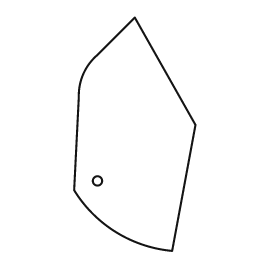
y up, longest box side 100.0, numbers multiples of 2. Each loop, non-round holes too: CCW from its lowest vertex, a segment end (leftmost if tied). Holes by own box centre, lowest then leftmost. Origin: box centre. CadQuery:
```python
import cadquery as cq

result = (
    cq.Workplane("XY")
    .moveTo(16.0, -50.0)
    .lineTo(26.0, 4.0)
    .lineTo(0.0, 50.0)
    .lineTo(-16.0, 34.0)
    .threePointArc((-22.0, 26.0), (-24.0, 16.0))
    .lineTo(-26.0, -24.0)
    .threePointArc((-8.0, -42.0), (16.0, -50.0))
    .close()
    .moveTo(-16.0, -20.0)
    .circle(2.0)
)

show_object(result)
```